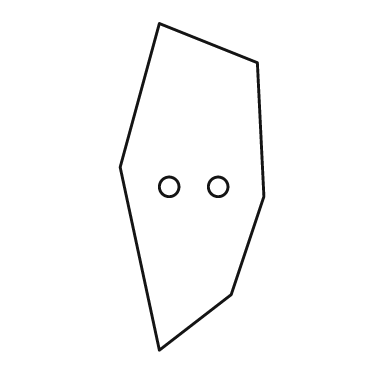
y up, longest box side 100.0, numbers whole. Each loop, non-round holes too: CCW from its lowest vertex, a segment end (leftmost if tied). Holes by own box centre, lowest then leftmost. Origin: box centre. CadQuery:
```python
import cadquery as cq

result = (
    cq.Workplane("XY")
    .moveTo(-10.0, -50.0)
    .lineTo(12.0, -33.0)
    .lineTo(22.0, -3.0)
    .lineTo(20.0, 38.0)
    .lineTo(-10.0, 50.0)
    .lineTo(-22.0, 6.0)
    .close()
    .moveTo(-7.0, 0.0)
    .circle(3.0)
    .moveTo(8.0, 0.0)
    .circle(3.0)
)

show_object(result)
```